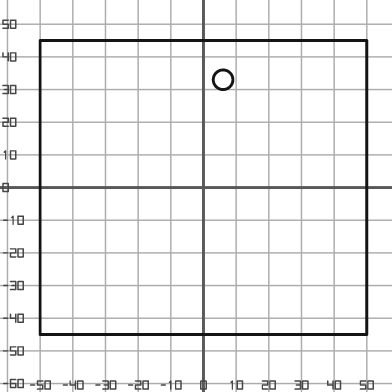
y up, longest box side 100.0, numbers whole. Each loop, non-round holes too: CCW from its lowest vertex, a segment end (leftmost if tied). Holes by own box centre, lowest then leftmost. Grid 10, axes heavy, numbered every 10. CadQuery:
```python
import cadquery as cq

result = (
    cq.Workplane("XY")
    .moveTo(-50.0, -45.0)
    .lineTo(50.0, -45.0)
    .lineTo(50.0, 45.0)
    .lineTo(-50.0, 45.0)
    .close()
    .moveTo(6.0, 33.0)
    .circle(3.0)
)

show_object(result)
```